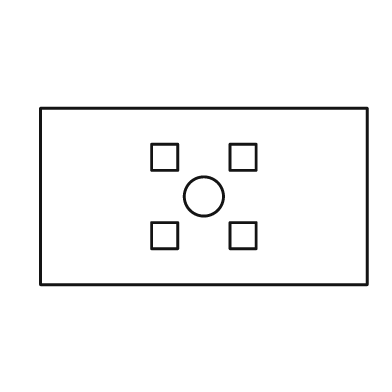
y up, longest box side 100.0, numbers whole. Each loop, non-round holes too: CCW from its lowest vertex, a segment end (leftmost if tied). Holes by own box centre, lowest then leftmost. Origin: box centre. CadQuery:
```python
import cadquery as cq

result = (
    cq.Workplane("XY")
    .moveTo(-50.0, -27.0)
    .lineTo(50.0, -27.0)
    .lineTo(50.0, 27.0)
    .lineTo(-50.0, 27.0)
    .close()
    .moveTo(-16.0, -16.0)
    .lineTo(-8.0, -16.0)
    .lineTo(-8.0, -8.0)
    .lineTo(-16.0, -8.0)
    .close()
    .moveTo(8.0, -16.0)
    .lineTo(16.0, -16.0)
    .lineTo(16.0, -8.0)
    .lineTo(8.0, -8.0)
    .close()
    .moveTo(0.0, 0.0)
    .circle(6.0)
    .moveTo(-16.0, 8.0)
    .lineTo(-8.0, 8.0)
    .lineTo(-8.0, 16.0)
    .lineTo(-16.0, 16.0)
    .close()
    .moveTo(8.0, 8.0)
    .lineTo(16.0, 8.0)
    .lineTo(16.0, 16.0)
    .lineTo(8.0, 16.0)
    .close()
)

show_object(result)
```